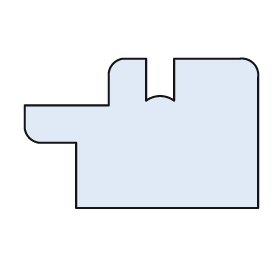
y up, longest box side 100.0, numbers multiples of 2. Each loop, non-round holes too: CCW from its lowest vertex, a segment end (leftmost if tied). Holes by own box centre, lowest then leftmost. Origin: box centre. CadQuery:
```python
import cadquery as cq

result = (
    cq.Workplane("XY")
    .moveTo(-28.0, -32.0)
    .lineTo(50.0, -32.0)
    .lineTo(50.0, 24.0)
    .threePointArc((48.0, 30.0), (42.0, 32.0))
    .lineTo(14.0, 32.0)
    .lineTo(14.0, 14.0)
    .threePointArc((8.0, 16.0), (2.0, 14.0))
    .lineTo(2.0, 32.0)
    .lineTo(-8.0, 32.0)
    .threePointArc((-12.0, 30.0), (-14.0, 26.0))
    .lineTo(-14.0, 12.0)
    .lineTo(-50.0, 12.0)
    .lineTo(-50.0, 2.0)
    .threePointArc((-48.0, -2.0), (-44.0, -4.0))
    .lineTo(-28.0, -4.0)
    .close()
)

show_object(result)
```